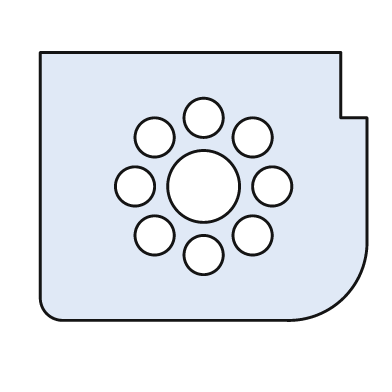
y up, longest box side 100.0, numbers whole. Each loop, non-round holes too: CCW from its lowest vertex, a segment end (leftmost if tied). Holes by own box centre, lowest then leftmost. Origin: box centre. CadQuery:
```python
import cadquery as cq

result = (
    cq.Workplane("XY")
    .moveTo(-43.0, -41.0)
    .lineTo(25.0, -41.0)
    .threePointArc((43.0, -34.0), (50.0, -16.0))
    .lineTo(50.0, 21.0)
    .lineTo(42.0, 21.0)
    .lineTo(42.0, 41.0)
    .lineTo(-50.0, 41.0)
    .lineTo(-50.0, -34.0)
    .threePointArc((-48.0, -39.0), (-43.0, -41.0))
    .close()
    .moveTo(0.0, -21.0)
    .circle(6.0)
    .moveTo(-15.0, -15.0)
    .circle(6.0)
    .moveTo(15.0, -15.0)
    .circle(6.0)
    .moveTo(-21.0, 0.0)
    .circle(6.0)
    .moveTo(0.0, 0.0)
    .circle(11.0)
    .moveTo(21.0, 0.0)
    .circle(6.0)
    .moveTo(-15.0, 15.0)
    .circle(6.0)
    .moveTo(15.0, 15.0)
    .circle(6.0)
    .moveTo(0.0, 21.0)
    .circle(6.0)
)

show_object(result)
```